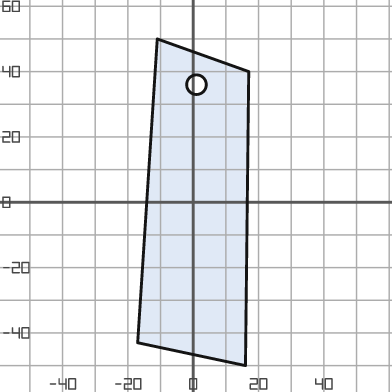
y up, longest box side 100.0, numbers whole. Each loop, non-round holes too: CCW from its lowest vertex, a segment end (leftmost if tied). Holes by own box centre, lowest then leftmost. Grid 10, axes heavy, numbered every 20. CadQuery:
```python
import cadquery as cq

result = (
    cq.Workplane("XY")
    .moveTo(16.0, -50.0)
    .lineTo(17.0, 40.0)
    .lineTo(-11.0, 50.0)
    .lineTo(-17.0, -43.0)
    .close()
    .moveTo(1.0, 36.0)
    .circle(3.0)
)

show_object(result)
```